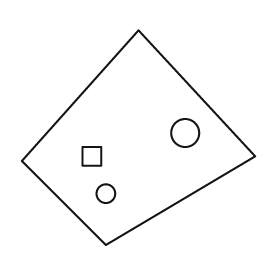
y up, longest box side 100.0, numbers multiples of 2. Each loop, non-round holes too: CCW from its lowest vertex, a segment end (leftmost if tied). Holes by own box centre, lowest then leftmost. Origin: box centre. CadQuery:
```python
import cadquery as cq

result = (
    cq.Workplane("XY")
    .moveTo(-14.0, -46.0)
    .lineTo(50.0, -8.0)
    .lineTo(0.0, 46.0)
    .lineTo(-50.0, -10.0)
    .close()
    .moveTo(-14.0, -24.0)
    .circle(4.0)
    .moveTo(-24.0, -12.0)
    .lineTo(-16.0, -12.0)
    .lineTo(-16.0, -4.0)
    .lineTo(-24.0, -4.0)
    .close()
    .moveTo(20.0, 2.0)
    .circle(6.0)
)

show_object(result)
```